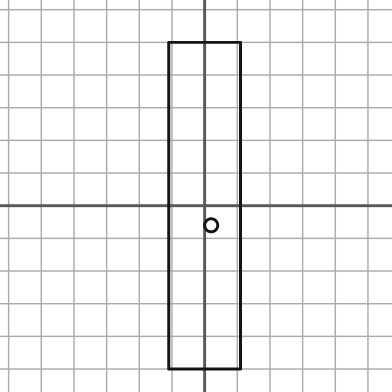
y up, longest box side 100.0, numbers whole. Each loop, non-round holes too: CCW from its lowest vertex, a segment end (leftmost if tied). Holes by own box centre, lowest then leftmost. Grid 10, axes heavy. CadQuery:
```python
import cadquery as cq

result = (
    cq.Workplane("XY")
    .moveTo(-11.0, -50.0)
    .lineTo(11.0, -50.0)
    .lineTo(11.0, 50.0)
    .lineTo(-11.0, 50.0)
    .close()
    .moveTo(2.0, -6.0)
    .circle(2.0)
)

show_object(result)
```